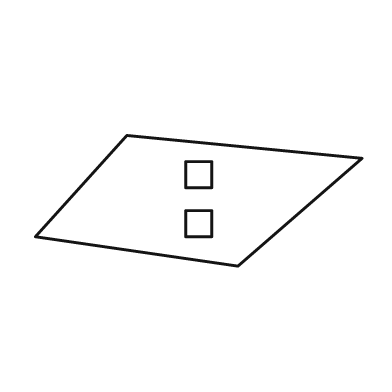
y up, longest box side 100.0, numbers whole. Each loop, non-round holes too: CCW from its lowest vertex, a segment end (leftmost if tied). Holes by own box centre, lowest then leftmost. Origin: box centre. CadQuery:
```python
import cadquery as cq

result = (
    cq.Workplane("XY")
    .moveTo(12.0, -20.0)
    .lineTo(50.0, 13.0)
    .lineTo(-22.0, 20.0)
    .lineTo(-50.0, -11.0)
    .close()
    .moveTo(-4.0, -11.0)
    .lineTo(4.0, -11.0)
    .lineTo(4.0, -3.0)
    .lineTo(-4.0, -3.0)
    .close()
    .moveTo(-4.0, 4.0)
    .lineTo(4.0, 4.0)
    .lineTo(4.0, 12.0)
    .lineTo(-4.0, 12.0)
    .close()
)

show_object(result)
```